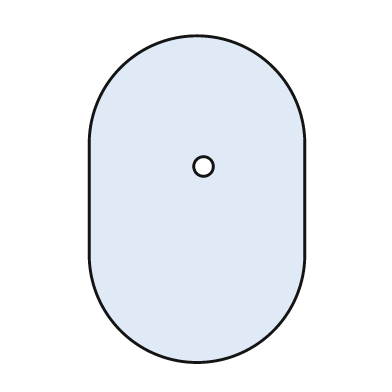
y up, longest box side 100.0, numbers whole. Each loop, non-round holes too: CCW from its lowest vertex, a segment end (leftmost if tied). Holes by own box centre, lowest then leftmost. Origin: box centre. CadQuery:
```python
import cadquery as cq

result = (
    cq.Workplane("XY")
    .moveTo(-33.0, -17.0)
    .threePointArc((0.0, -50.0), (33.0, -17.0))
    .lineTo(33.0, 17.0)
    .threePointArc((0.0, 50.0), (-33.0, 17.0))
    .close()
    .moveTo(2.0, 10.0)
    .circle(3.0)
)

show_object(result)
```